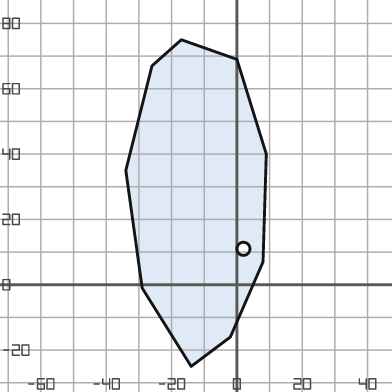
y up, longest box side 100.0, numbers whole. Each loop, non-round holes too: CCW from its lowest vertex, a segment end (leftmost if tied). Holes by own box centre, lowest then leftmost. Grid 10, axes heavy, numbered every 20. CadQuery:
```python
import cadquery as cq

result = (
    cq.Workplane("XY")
    .moveTo(-14.0, -25.0)
    .lineTo(-2.0, -16.0)
    .lineTo(8.0, 7.0)
    .lineTo(9.0, 40.0)
    .lineTo(0.0, 69.0)
    .lineTo(-17.0, 75.0)
    .lineTo(-26.0, 67.0)
    .lineTo(-34.0, 35.0)
    .lineTo(-29.0, -1.0)
    .close()
    .moveTo(2.0, 11.0)
    .circle(2.0)
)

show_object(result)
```